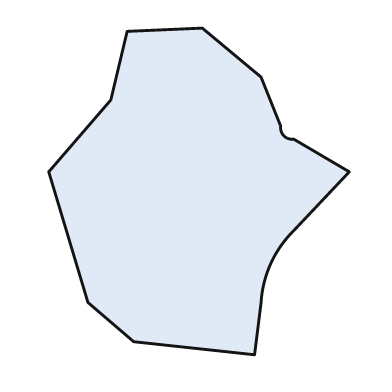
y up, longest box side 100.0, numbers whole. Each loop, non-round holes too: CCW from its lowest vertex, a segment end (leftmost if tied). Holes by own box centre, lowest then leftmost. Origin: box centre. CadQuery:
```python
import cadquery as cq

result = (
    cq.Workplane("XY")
    .moveTo(17.0, -50.0)
    .lineTo(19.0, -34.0)
    .threePointArc((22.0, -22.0), (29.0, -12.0))
    .lineTo(46.0, 6.0)
    .lineTo(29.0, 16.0)
    .threePointArc((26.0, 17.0), (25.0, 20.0))
    .lineTo(19.0, 35.0)
    .lineTo(1.0, 50.0)
    .lineTo(-22.0, 49.0)
    .lineTo(-27.0, 28.0)
    .lineTo(-46.0, 6.0)
    .lineTo(-34.0, -34.0)
    .lineTo(-20.0, -46.0)
    .close()
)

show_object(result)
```